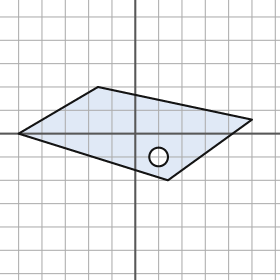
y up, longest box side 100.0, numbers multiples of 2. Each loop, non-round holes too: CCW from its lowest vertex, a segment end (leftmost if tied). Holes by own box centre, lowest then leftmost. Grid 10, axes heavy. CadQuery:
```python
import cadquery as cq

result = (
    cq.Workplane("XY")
    .moveTo(14.0, -20.0)
    .lineTo(50.0, 6.0)
    .lineTo(-16.0, 20.0)
    .lineTo(-50.0, 0.0)
    .close()
    .moveTo(10.0, -10.0)
    .circle(4.0)
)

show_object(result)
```